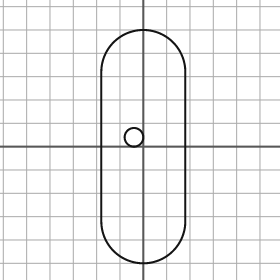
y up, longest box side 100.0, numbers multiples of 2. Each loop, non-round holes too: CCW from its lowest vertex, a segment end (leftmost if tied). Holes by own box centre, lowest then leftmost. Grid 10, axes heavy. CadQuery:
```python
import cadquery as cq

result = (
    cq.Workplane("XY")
    .moveTo(-18.0, -32.0)
    .threePointArc((0.0, -50.0), (18.0, -32.0))
    .lineTo(18.0, 32.0)
    .threePointArc((0.0, 50.0), (-18.0, 32.0))
    .close()
    .moveTo(-4.0, 4.0)
    .circle(4.0)
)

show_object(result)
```